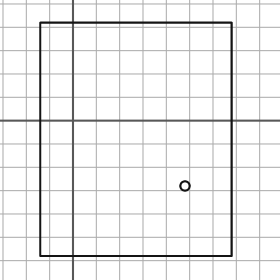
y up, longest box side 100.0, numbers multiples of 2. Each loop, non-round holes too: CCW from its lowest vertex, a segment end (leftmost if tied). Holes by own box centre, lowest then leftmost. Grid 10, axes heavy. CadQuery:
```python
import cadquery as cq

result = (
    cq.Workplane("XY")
    .moveTo(-14.0, -58.0)
    .lineTo(68.0, -58.0)
    .lineTo(68.0, 42.0)
    .lineTo(-14.0, 42.0)
    .close()
    .moveTo(48.0, -28.0)
    .circle(2.0)
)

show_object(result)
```